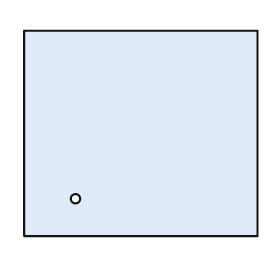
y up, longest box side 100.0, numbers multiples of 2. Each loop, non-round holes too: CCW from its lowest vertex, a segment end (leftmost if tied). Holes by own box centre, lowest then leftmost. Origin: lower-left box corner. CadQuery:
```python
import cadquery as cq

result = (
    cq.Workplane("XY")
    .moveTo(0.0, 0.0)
    .lineTo(100.0, 0.0)
    .lineTo(100.0, 88.0)
    .lineTo(0.0, 88.0)
    .close()
    .moveTo(22.0, 16.0)
    .circle(2.0)
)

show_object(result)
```